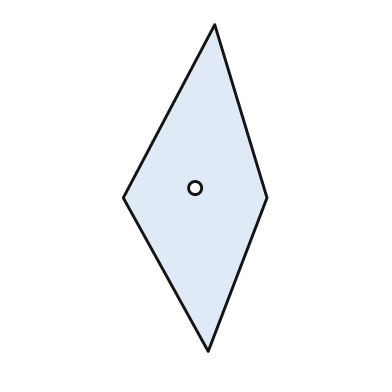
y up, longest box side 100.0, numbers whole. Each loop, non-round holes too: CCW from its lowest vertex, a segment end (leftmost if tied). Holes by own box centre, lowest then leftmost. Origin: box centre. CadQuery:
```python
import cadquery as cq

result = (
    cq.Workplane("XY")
    .moveTo(4.0, -50.0)
    .lineTo(22.0, -3.0)
    .lineTo(6.0, 50.0)
    .lineTo(-22.0, -3.0)
    .close()
    .moveTo(0.0, 0.0)
    .circle(2.0)
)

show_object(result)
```